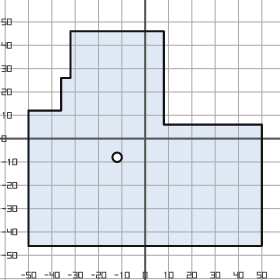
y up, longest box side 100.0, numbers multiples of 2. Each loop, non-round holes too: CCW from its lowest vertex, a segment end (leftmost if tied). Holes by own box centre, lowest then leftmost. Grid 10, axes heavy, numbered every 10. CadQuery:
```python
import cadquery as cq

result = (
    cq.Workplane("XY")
    .moveTo(-50.0, -46.0)
    .lineTo(50.0, -46.0)
    .lineTo(50.0, 6.0)
    .lineTo(8.0, 6.0)
    .lineTo(8.0, 46.0)
    .lineTo(-32.0, 46.0)
    .lineTo(-32.0, 26.0)
    .lineTo(-36.0, 26.0)
    .lineTo(-36.0, 12.0)
    .lineTo(-50.0, 12.0)
    .close()
    .moveTo(-12.0, -8.0)
    .circle(2.0)
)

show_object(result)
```